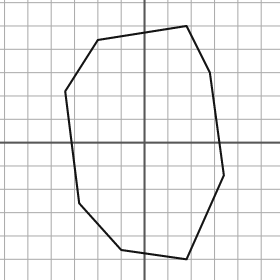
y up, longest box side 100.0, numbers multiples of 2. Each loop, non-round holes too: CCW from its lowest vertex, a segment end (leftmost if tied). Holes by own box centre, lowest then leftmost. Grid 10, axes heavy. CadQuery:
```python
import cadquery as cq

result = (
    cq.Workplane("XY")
    .moveTo(18.0, -50.0)
    .lineTo(34.0, -14.0)
    .lineTo(28.0, 30.0)
    .lineTo(18.0, 50.0)
    .lineTo(-20.0, 44.0)
    .lineTo(-34.0, 22.0)
    .lineTo(-28.0, -26.0)
    .lineTo(-10.0, -46.0)
    .close()
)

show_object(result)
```